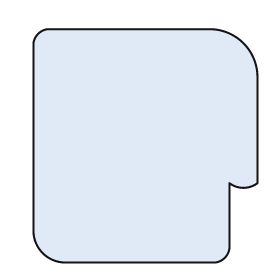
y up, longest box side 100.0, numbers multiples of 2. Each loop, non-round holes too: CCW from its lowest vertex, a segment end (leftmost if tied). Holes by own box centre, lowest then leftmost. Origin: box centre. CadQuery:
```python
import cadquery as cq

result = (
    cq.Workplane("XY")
    .moveTo(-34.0, -50.0)
    .lineTo(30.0, -50.0)
    .threePointArc((34.0, -48.0), (36.0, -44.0))
    .lineTo(36.0, -16.0)
    .threePointArc((42.0, -18.0), (48.0, -16.0))
    .lineTo(48.0, 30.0)
    .threePointArc((42.0, 44.0), (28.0, 50.0))
    .lineTo(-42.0, 50.0)
    .threePointArc((-46.0, 48.0), (-48.0, 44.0))
    .lineTo(-48.0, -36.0)
    .threePointArc((-44.0, -46.0), (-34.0, -50.0))
    .close()
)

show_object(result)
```